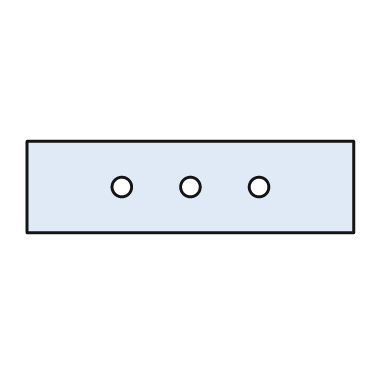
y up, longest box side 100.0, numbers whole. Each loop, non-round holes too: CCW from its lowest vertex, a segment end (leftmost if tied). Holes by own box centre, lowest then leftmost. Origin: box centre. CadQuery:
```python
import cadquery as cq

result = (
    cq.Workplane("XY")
    .moveTo(-50.0, -14.0)
    .lineTo(50.0, -14.0)
    .lineTo(50.0, 14.0)
    .lineTo(-50.0, 14.0)
    .close()
    .moveTo(-21.0, 0.0)
    .circle(3.0)
    .moveTo(0.0, 0.0)
    .circle(3.0)
    .moveTo(21.0, 0.0)
    .circle(3.0)
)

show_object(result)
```